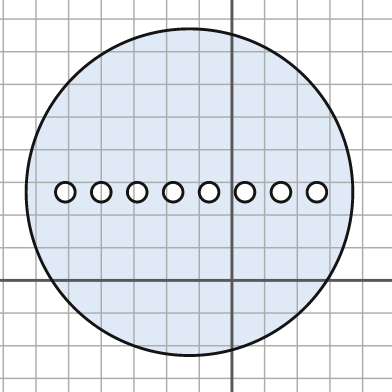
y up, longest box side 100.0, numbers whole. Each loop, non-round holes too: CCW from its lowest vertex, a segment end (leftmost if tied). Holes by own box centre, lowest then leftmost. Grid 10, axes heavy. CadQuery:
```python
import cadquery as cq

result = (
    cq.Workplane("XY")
    .moveTo(-13.0, 27.0)
    .circle(50.0)
    .moveTo(-51.0, 27.0)
    .circle(3.0)
    .moveTo(-40.0, 27.0)
    .circle(3.0)
    .moveTo(-29.0, 27.0)
    .circle(3.0)
    .moveTo(-18.0, 27.0)
    .circle(3.0)
    .moveTo(-7.0, 27.0)
    .circle(3.0)
    .moveTo(4.0, 27.0)
    .circle(3.0)
    .moveTo(15.0, 27.0)
    .circle(3.0)
    .moveTo(26.0, 27.0)
    .circle(3.0)
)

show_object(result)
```